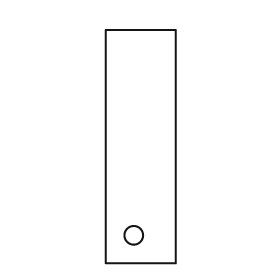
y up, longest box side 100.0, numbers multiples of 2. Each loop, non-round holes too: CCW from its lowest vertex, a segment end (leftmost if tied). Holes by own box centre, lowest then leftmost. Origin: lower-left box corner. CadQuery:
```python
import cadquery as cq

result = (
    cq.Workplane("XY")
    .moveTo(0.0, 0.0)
    .lineTo(30.0, 0.0)
    .lineTo(30.0, 100.0)
    .lineTo(0.0, 100.0)
    .close()
    .moveTo(12.0, 12.0)
    .circle(4.0)
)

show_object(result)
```